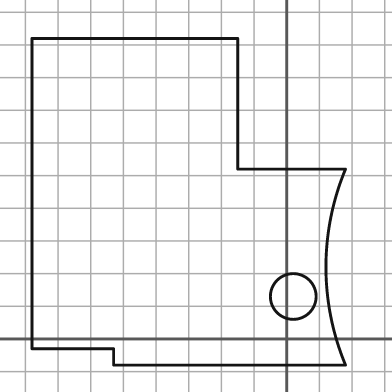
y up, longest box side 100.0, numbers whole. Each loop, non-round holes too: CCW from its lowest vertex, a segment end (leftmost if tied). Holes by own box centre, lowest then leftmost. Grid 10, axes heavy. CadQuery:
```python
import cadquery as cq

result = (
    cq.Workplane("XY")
    .moveTo(-53.0, -8.0)
    .lineTo(18.0, -8.0)
    .threePointArc((12.0, 22.0), (18.0, 52.0))
    .lineTo(-15.0, 52.0)
    .lineTo(-15.0, 92.0)
    .lineTo(-78.0, 92.0)
    .lineTo(-78.0, -3.0)
    .lineTo(-53.0, -3.0)
    .close()
    .moveTo(2.0, 13.0)
    .circle(7.0)
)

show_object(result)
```